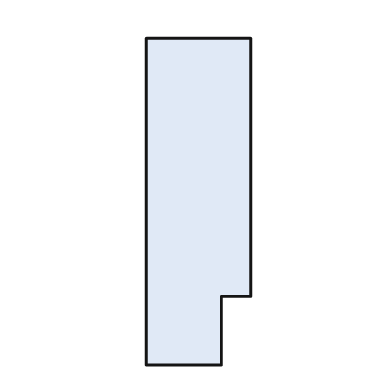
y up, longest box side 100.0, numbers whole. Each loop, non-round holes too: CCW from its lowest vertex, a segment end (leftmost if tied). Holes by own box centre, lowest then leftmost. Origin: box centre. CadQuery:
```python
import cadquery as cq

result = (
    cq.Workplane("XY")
    .moveTo(-16.0, -50.0)
    .lineTo(7.0, -50.0)
    .lineTo(7.0, -29.0)
    .lineTo(16.0, -29.0)
    .lineTo(16.0, 50.0)
    .lineTo(-16.0, 50.0)
    .close()
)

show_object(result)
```